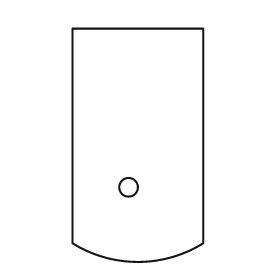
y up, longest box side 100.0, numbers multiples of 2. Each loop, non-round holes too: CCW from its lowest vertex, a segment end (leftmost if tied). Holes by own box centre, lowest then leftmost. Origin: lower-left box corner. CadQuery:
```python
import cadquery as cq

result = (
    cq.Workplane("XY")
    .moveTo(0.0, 8.0)
    .threePointArc((28.0, 0.0), (56.0, 8.0))
    .lineTo(56.0, 100.0)
    .lineTo(0.0, 100.0)
    .close()
    .moveTo(24.0, 32.0)
    .circle(4.0)
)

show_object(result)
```